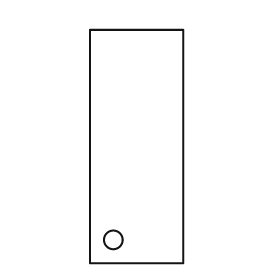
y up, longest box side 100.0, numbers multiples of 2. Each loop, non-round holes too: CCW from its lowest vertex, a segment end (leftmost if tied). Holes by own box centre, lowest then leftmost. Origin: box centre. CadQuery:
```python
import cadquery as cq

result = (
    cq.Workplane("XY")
    .moveTo(-20.0, -50.0)
    .lineTo(20.0, -50.0)
    .lineTo(20.0, 50.0)
    .lineTo(-20.0, 50.0)
    .close()
    .moveTo(-10.0, -40.0)
    .circle(4.0)
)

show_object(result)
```